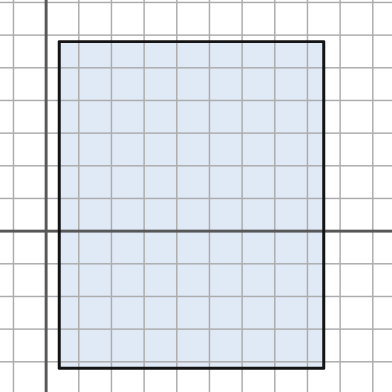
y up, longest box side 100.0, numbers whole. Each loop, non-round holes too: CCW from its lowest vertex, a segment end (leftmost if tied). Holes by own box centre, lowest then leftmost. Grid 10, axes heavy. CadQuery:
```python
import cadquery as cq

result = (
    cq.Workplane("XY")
    .moveTo(4.0, -42.0)
    .lineTo(85.0, -42.0)
    .lineTo(85.0, 58.0)
    .lineTo(4.0, 58.0)
    .close()
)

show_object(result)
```